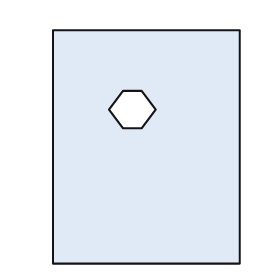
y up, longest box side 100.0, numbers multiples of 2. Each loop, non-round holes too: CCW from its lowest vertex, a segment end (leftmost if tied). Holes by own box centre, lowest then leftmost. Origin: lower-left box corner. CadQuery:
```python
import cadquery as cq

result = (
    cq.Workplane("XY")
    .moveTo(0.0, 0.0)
    .lineTo(80.0, 0.0)
    .lineTo(80.0, 100.0)
    .lineTo(0.0, 100.0)
    .close()
    .moveTo(30.0, 58.0)
    .lineTo(38.0, 58.0)
    .lineTo(44.0, 66.0)
    .lineTo(38.0, 74.0)
    .lineTo(30.0, 74.0)
    .lineTo(24.0, 66.0)
    .close()
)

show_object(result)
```